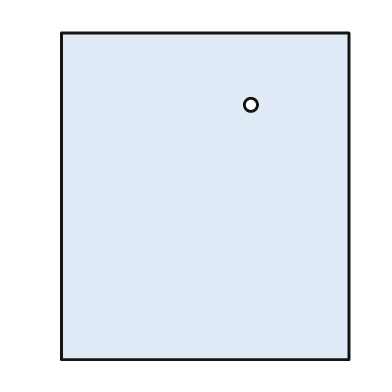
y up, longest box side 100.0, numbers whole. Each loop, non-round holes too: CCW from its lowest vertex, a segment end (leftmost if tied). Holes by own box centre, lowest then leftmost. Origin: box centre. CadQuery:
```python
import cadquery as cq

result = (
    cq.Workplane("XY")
    .moveTo(-44.0, -50.0)
    .lineTo(44.0, -50.0)
    .lineTo(44.0, 50.0)
    .lineTo(-44.0, 50.0)
    .close()
    .moveTo(14.0, 28.0)
    .circle(2.0)
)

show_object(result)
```